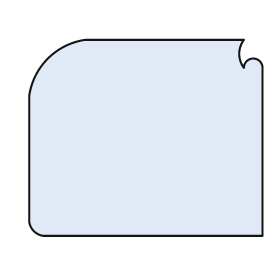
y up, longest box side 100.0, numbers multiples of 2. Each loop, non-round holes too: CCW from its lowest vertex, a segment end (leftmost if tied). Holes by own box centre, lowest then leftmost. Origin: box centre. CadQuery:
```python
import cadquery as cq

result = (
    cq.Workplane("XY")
    .moveTo(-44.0, -42.0)
    .lineTo(50.0, -42.0)
    .lineTo(50.0, 30.0)
    .threePointArc((46.0, 34.0), (42.0, 30.0))
    .threePointArc((40.0, 36.0), (42.0, 42.0))
    .lineTo(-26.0, 42.0)
    .threePointArc((-42.0, 34.0), (-50.0, 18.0))
    .lineTo(-50.0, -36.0)
    .threePointArc((-48.0, -40.0), (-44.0, -42.0))
    .close()
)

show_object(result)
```